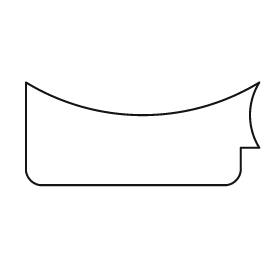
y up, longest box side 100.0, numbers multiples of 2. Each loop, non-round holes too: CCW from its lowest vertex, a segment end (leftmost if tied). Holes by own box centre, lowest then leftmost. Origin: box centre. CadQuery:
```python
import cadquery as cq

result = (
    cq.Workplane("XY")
    .moveTo(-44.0, -22.0)
    .lineTo(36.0, -22.0)
    .threePointArc((40.0, -20.0), (42.0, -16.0))
    .lineTo(42.0, -6.0)
    .lineTo(50.0, -6.0)
    .threePointArc((46.0, 8.0), (50.0, 22.0))
    .threePointArc((0.0, 8.0), (-50.0, 22.0))
    .lineTo(-50.0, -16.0)
    .threePointArc((-48.0, -20.0), (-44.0, -22.0))
    .close()
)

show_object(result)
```